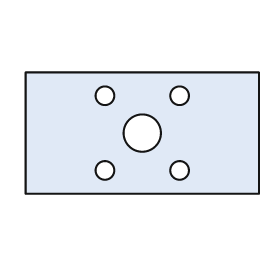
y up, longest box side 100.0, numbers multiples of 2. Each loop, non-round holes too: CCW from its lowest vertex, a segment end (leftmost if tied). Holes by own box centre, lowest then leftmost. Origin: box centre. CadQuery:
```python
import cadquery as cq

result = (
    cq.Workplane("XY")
    .moveTo(-50.0, -26.0)
    .lineTo(50.0, -26.0)
    .lineTo(50.0, 26.0)
    .lineTo(-50.0, 26.0)
    .close()
    .moveTo(-16.0, -16.0)
    .circle(4.0)
    .moveTo(16.0, -16.0)
    .circle(4.0)
    .moveTo(0.0, 0.0)
    .circle(8.0)
    .moveTo(-16.0, 16.0)
    .circle(4.0)
    .moveTo(16.0, 16.0)
    .circle(4.0)
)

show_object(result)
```